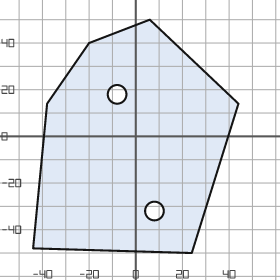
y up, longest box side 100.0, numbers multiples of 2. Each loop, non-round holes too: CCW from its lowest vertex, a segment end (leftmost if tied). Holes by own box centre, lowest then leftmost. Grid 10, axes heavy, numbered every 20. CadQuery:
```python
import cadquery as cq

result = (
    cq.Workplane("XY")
    .moveTo(24.0, -50.0)
    .lineTo(44.0, 14.0)
    .lineTo(6.0, 50.0)
    .lineTo(-20.0, 40.0)
    .lineTo(-38.0, 14.0)
    .lineTo(-44.0, -48.0)
    .close()
    .moveTo(8.0, -32.0)
    .circle(4.0)
    .moveTo(-8.0, 18.0)
    .circle(4.0)
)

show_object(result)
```